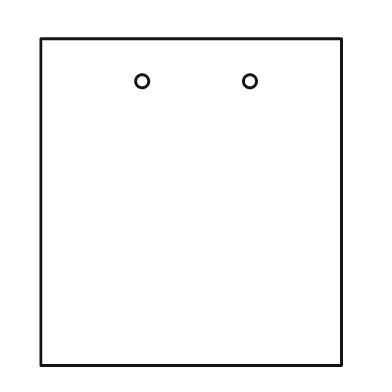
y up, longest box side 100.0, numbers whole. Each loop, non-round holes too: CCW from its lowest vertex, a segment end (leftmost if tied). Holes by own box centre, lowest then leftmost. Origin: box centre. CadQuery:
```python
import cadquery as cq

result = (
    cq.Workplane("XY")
    .moveTo(-46.0, -50.0)
    .lineTo(46.0, -50.0)
    .lineTo(46.0, 50.0)
    .lineTo(-46.0, 50.0)
    .close()
    .moveTo(-15.0, 37.0)
    .circle(2.0)
    .moveTo(18.0, 37.0)
    .circle(2.0)
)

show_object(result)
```